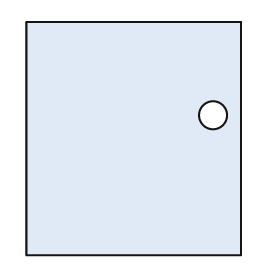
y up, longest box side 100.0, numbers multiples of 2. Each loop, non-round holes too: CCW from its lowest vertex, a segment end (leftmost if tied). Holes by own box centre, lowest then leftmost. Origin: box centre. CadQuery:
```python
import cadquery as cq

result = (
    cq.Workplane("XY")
    .moveTo(-46.0, -50.0)
    .lineTo(46.0, -50.0)
    .lineTo(46.0, 50.0)
    .lineTo(-46.0, 50.0)
    .close()
    .moveTo(34.0, 10.0)
    .circle(6.0)
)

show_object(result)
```